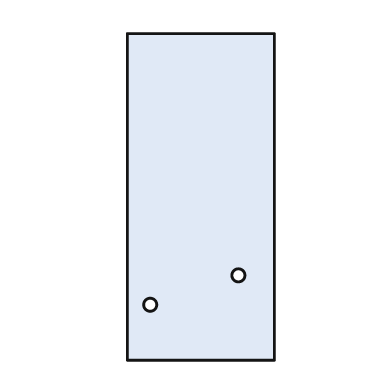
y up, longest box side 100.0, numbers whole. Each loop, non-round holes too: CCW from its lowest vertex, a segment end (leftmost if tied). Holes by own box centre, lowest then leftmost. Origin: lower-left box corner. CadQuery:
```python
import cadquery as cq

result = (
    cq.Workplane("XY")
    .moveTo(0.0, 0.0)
    .lineTo(45.0, 0.0)
    .lineTo(45.0, 100.0)
    .lineTo(0.0, 100.0)
    .close()
    .moveTo(7.0, 17.0)
    .circle(2.0)
    .moveTo(34.0, 26.0)
    .circle(2.0)
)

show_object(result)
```